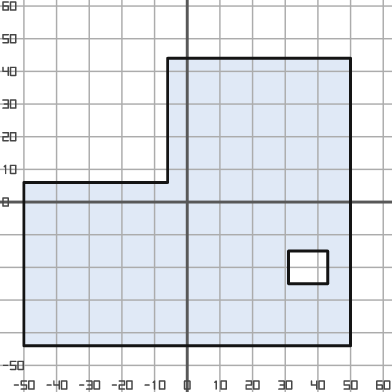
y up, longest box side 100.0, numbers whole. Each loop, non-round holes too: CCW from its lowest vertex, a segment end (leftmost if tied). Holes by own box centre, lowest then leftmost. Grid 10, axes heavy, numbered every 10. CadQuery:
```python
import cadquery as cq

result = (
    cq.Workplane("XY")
    .moveTo(-50.0, -44.0)
    .lineTo(50.0, -44.0)
    .lineTo(50.0, 44.0)
    .lineTo(-6.0, 44.0)
    .lineTo(-6.0, 6.0)
    .lineTo(-50.0, 6.0)
    .close()
    .moveTo(31.0, -25.0)
    .lineTo(43.0, -25.0)
    .lineTo(43.0, -15.0)
    .lineTo(31.0, -15.0)
    .close()
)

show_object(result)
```